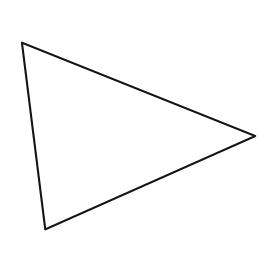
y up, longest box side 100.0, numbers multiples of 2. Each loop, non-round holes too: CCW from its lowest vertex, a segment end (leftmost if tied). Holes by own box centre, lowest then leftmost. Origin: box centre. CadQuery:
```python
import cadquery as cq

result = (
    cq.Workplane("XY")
    .moveTo(-40.0, -40.0)
    .lineTo(50.0, 0.0)
    .lineTo(-50.0, 40.0)
    .close()
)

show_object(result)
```